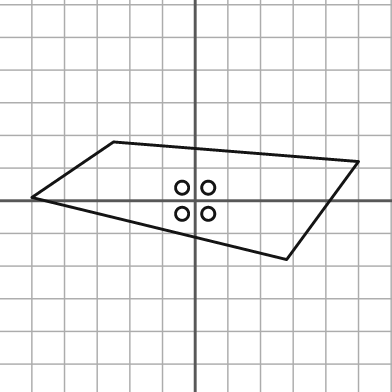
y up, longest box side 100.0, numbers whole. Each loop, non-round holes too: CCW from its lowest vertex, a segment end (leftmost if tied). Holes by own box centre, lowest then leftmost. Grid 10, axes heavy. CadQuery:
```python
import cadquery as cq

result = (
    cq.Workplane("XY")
    .moveTo(28.0, -18.0)
    .lineTo(50.0, 12.0)
    .lineTo(-25.0, 18.0)
    .lineTo(-50.0, 1.0)
    .close()
    .moveTo(-4.0, -4.0)
    .circle(2.0)
    .moveTo(4.0, -4.0)
    .circle(2.0)
    .moveTo(-4.0, 4.0)
    .circle(2.0)
    .moveTo(4.0, 4.0)
    .circle(2.0)
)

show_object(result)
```